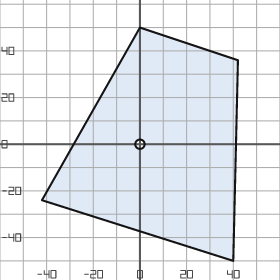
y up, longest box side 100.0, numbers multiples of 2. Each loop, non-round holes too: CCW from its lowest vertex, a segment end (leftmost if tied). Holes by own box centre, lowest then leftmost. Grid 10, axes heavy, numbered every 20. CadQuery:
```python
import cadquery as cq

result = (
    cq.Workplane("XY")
    .moveTo(40.0, -50.0)
    .lineTo(42.0, 36.0)
    .lineTo(0.0, 50.0)
    .lineTo(-42.0, -24.0)
    .close()
    .moveTo(0.0, 0.0)
    .circle(2.0)
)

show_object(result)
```